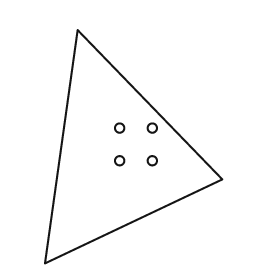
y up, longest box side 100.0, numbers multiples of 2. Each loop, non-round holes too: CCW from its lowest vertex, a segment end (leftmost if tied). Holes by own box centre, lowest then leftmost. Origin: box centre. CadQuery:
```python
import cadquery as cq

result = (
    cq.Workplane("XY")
    .moveTo(-38.0, -50.0)
    .lineTo(38.0, -14.0)
    .lineTo(-24.0, 50.0)
    .close()
    .moveTo(-6.0, -6.0)
    .circle(2.0)
    .moveTo(8.0, -6.0)
    .circle(2.0)
    .moveTo(-6.0, 8.0)
    .circle(2.0)
    .moveTo(8.0, 8.0)
    .circle(2.0)
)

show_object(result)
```